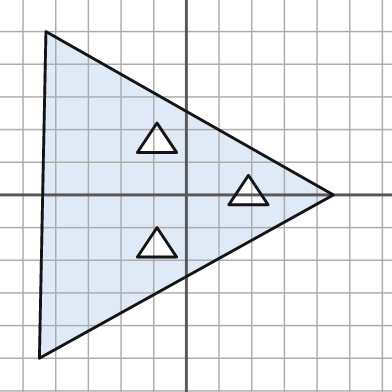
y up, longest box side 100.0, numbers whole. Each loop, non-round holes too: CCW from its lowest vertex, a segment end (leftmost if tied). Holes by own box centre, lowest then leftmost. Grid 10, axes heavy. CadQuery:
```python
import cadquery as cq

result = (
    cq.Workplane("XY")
    .moveTo(-45.0, -50.0)
    .lineTo(45.0, 0.0)
    .lineTo(-43.0, 50.0)
    .close()
    .moveTo(-15.0, -19.0)
    .lineTo(-3.0, -19.0)
    .lineTo(-9.0, -10.0)
    .close()
    .moveTo(13.0, -3.0)
    .lineTo(25.0, -3.0)
    .lineTo(19.0, 6.0)
    .close()
    .moveTo(-15.0, 13.0)
    .lineTo(-3.0, 13.0)
    .lineTo(-9.0, 22.0)
    .close()
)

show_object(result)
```